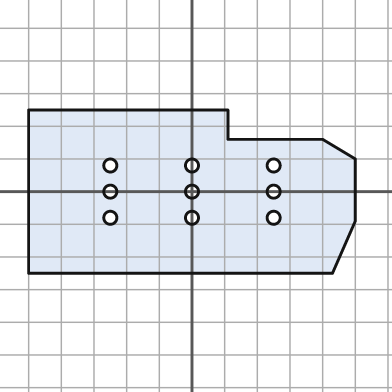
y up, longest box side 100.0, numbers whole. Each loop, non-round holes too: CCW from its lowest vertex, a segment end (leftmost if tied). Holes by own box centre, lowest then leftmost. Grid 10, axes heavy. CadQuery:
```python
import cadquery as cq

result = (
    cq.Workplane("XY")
    .moveTo(-50.0, -25.0)
    .lineTo(43.0, -25.0)
    .lineTo(50.0, -9.0)
    .lineTo(50.0, 10.0)
    .lineTo(40.0, 16.0)
    .lineTo(11.0, 16.0)
    .lineTo(11.0, 25.0)
    .lineTo(-50.0, 25.0)
    .close()
    .moveTo(-25.0, -8.0)
    .circle(2.0)
    .moveTo(0.0, -8.0)
    .circle(2.0)
    .moveTo(25.0, -8.0)
    .circle(2.0)
    .moveTo(-25.0, 0.0)
    .circle(2.0)
    .moveTo(0.0, 0.0)
    .circle(2.0)
    .moveTo(25.0, 0.0)
    .circle(2.0)
    .moveTo(-25.0, 8.0)
    .circle(2.0)
    .moveTo(0.0, 8.0)
    .circle(2.0)
    .moveTo(25.0, 8.0)
    .circle(2.0)
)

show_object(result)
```